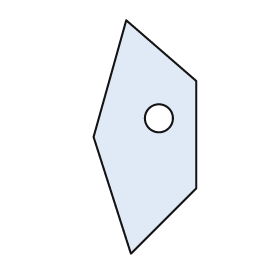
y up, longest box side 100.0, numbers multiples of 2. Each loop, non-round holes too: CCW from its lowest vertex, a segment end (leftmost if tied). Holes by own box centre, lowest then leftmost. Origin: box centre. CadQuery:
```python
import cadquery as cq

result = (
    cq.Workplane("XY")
    .moveTo(-6.0, -50.0)
    .lineTo(22.0, -22.0)
    .lineTo(22.0, 24.0)
    .lineTo(-8.0, 50.0)
    .lineTo(-22.0, 0.0)
    .close()
    .moveTo(6.0, 8.0)
    .circle(6.0)
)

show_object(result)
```